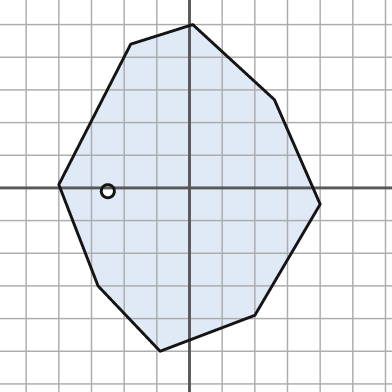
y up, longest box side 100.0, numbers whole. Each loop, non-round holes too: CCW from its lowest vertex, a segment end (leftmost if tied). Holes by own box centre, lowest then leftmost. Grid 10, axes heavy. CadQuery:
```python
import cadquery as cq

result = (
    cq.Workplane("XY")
    .moveTo(-9.0, -50.0)
    .lineTo(20.0, -39.0)
    .lineTo(40.0, -5.0)
    .lineTo(26.0, 27.0)
    .lineTo(1.0, 50.0)
    .lineTo(-18.0, 44.0)
    .lineTo(-40.0, 1.0)
    .lineTo(-28.0, -30.0)
    .close()
    .moveTo(-25.0, -1.0)
    .circle(2.0)
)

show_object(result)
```